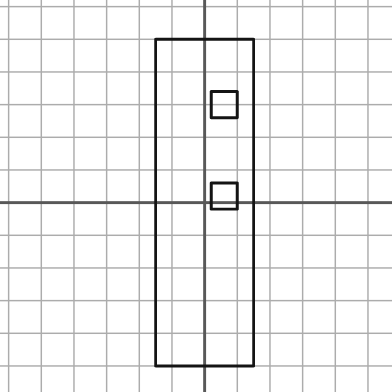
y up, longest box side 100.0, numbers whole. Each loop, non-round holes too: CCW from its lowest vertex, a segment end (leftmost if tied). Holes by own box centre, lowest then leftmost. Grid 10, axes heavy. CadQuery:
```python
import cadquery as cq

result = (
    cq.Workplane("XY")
    .moveTo(-15.0, -50.0)
    .lineTo(15.0, -50.0)
    .lineTo(15.0, 50.0)
    .lineTo(-15.0, 50.0)
    .close()
    .moveTo(2.0, -2.0)
    .lineTo(10.0, -2.0)
    .lineTo(10.0, 6.0)
    .lineTo(2.0, 6.0)
    .close()
    .moveTo(2.0, 26.0)
    .lineTo(10.0, 26.0)
    .lineTo(10.0, 34.0)
    .lineTo(2.0, 34.0)
    .close()
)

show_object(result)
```